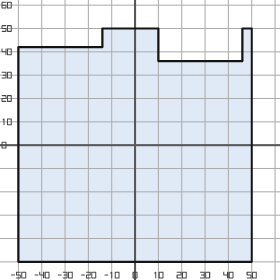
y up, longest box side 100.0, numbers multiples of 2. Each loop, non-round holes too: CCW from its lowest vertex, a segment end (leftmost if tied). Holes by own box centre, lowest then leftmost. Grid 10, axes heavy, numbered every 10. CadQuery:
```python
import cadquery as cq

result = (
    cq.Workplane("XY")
    .moveTo(-50.0, -50.0)
    .lineTo(50.0, -50.0)
    .lineTo(50.0, 50.0)
    .lineTo(46.0, 50.0)
    .lineTo(46.0, 36.0)
    .lineTo(10.0, 36.0)
    .lineTo(10.0, 50.0)
    .lineTo(-14.0, 50.0)
    .lineTo(-14.0, 42.0)
    .lineTo(-50.0, 42.0)
    .close()
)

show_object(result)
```